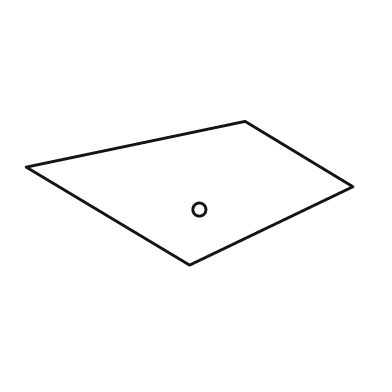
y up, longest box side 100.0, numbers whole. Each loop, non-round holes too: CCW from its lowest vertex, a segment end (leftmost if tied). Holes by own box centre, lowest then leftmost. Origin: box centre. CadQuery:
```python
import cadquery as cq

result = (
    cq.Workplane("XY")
    .moveTo(0.0, -22.0)
    .lineTo(50.0, 2.0)
    .lineTo(17.0, 22.0)
    .lineTo(-50.0, 8.0)
    .close()
    .moveTo(3.0, -5.0)
    .circle(2.0)
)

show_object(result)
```